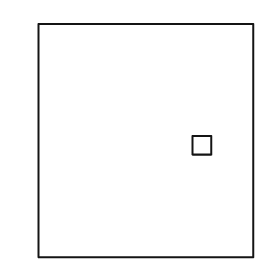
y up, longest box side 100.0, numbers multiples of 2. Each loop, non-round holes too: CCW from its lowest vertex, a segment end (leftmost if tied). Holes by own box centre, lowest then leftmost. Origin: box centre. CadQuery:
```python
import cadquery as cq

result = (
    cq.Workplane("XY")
    .moveTo(-46.0, -50.0)
    .lineTo(46.0, -50.0)
    .lineTo(46.0, 50.0)
    .lineTo(-46.0, 50.0)
    .close()
    .moveTo(20.0, -6.0)
    .lineTo(28.0, -6.0)
    .lineTo(28.0, 2.0)
    .lineTo(20.0, 2.0)
    .close()
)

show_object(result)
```